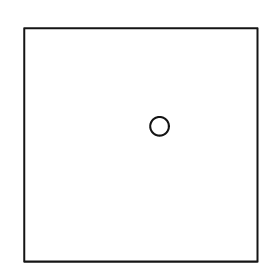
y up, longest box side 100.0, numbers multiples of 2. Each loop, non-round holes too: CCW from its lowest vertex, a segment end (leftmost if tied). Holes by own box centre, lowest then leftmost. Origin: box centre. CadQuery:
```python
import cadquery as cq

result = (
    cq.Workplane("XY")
    .moveTo(-50.0, -50.0)
    .lineTo(50.0, -50.0)
    .lineTo(50.0, 50.0)
    .lineTo(-50.0, 50.0)
    .close()
    .moveTo(8.0, 8.0)
    .circle(4.0)
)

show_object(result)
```